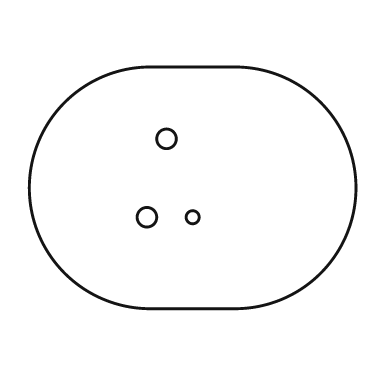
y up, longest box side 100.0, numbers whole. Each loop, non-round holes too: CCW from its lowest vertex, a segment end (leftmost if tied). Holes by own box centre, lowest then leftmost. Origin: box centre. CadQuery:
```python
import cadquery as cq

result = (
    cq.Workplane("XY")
    .moveTo(-13.0, -37.0)
    .lineTo(13.0, -37.0)
    .threePointArc((50.0, 0.0), (13.0, 37.0))
    .lineTo(-13.0, 37.0)
    .threePointArc((-50.0, 0.0), (-13.0, -37.0))
    .close()
    .moveTo(-14.0, -9.0)
    .circle(3.0)
    .moveTo(0.0, -9.0)
    .circle(2.0)
    .moveTo(-8.0, 15.0)
    .circle(3.0)
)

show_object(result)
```